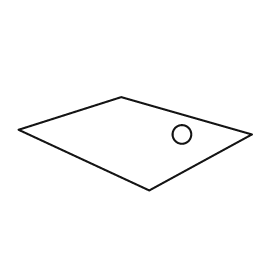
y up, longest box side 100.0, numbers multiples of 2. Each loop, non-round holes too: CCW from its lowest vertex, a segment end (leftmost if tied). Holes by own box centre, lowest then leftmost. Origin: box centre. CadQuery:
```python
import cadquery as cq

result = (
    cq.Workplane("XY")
    .moveTo(6.0, -20.0)
    .lineTo(50.0, 4.0)
    .lineTo(-6.0, 20.0)
    .lineTo(-50.0, 6.0)
    .close()
    .moveTo(20.0, 4.0)
    .circle(4.0)
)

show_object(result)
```